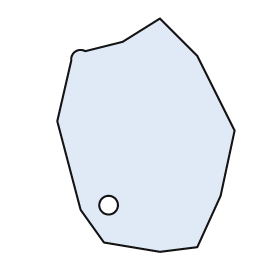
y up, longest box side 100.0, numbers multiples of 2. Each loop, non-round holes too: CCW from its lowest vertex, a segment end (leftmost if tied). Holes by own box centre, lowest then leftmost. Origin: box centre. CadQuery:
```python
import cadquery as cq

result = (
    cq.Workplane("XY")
    .moveTo(6.0, -50.0)
    .lineTo(22.0, -48.0)
    .lineTo(32.0, -26.0)
    .lineTo(38.0, 2.0)
    .lineTo(22.0, 34.0)
    .lineTo(6.0, 50.0)
    .lineTo(-10.0, 40.0)
    .lineTo(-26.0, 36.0)
    .threePointArc((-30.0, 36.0), (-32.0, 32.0))
    .lineTo(-38.0, 6.0)
    .lineTo(-28.0, -32.0)
    .lineTo(-18.0, -46.0)
    .close()
    .moveTo(-16.0, -30.0)
    .circle(4.0)
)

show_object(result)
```